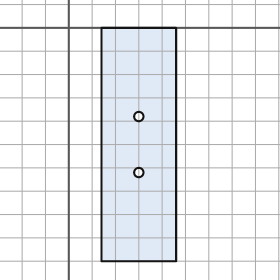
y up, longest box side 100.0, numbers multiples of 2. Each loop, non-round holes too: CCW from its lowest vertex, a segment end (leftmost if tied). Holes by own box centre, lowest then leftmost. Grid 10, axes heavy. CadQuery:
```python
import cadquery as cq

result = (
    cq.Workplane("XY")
    .moveTo(14.0, -100.0)
    .lineTo(46.0, -100.0)
    .lineTo(46.0, 0.0)
    .lineTo(14.0, 0.0)
    .close()
    .moveTo(30.0, -62.0)
    .circle(2.0)
    .moveTo(30.0, -38.0)
    .circle(2.0)
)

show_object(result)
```